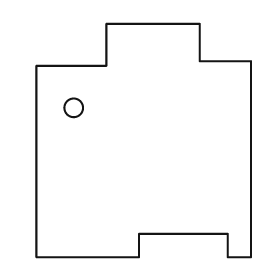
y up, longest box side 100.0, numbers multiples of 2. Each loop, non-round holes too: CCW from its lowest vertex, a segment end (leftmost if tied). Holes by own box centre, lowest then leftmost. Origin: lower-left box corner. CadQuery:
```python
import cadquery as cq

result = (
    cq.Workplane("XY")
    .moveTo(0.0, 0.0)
    .lineTo(44.0, 0.0)
    .lineTo(44.0, 10.0)
    .lineTo(82.0, 10.0)
    .lineTo(82.0, 0.0)
    .lineTo(92.0, 0.0)
    .lineTo(92.0, 84.0)
    .lineTo(70.0, 84.0)
    .lineTo(70.0, 100.0)
    .lineTo(30.0, 100.0)
    .lineTo(30.0, 82.0)
    .lineTo(0.0, 82.0)
    .close()
    .moveTo(16.0, 64.0)
    .circle(4.0)
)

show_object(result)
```